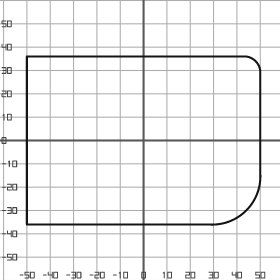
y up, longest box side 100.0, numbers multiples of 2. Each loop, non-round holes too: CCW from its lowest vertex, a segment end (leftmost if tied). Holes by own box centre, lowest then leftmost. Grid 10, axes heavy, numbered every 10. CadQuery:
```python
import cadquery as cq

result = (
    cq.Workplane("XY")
    .moveTo(-50.0, -36.0)
    .lineTo(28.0, -36.0)
    .threePointArc((44.0, -30.0), (50.0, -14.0))
    .lineTo(50.0, 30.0)
    .threePointArc((48.0, 34.0), (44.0, 36.0))
    .lineTo(-50.0, 36.0)
    .close()
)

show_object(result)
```